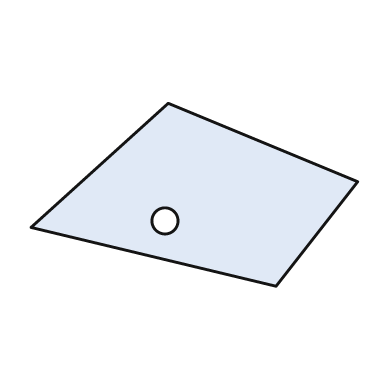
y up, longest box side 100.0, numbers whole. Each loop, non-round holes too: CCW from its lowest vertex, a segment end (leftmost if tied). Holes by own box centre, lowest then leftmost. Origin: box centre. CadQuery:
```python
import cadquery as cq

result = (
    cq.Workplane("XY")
    .moveTo(25.0, -28.0)
    .lineTo(50.0, 4.0)
    .lineTo(-8.0, 28.0)
    .lineTo(-50.0, -10.0)
    .close()
    .moveTo(-9.0, -8.0)
    .circle(4.0)
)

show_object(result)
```